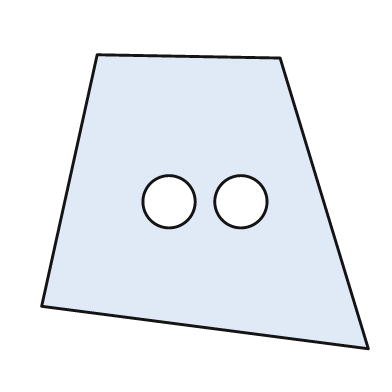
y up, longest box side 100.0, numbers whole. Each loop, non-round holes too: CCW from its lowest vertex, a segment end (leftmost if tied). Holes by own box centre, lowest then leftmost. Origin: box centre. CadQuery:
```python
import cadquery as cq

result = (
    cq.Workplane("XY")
    .moveTo(50.0, -45.0)
    .lineTo(23.0, 44.0)
    .lineTo(-33.0, 45.0)
    .lineTo(-50.0, -32.0)
    .close()
    .moveTo(-11.0, 0.0)
    .circle(8.0)
    .moveTo(11.0, 0.0)
    .circle(8.0)
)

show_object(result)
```